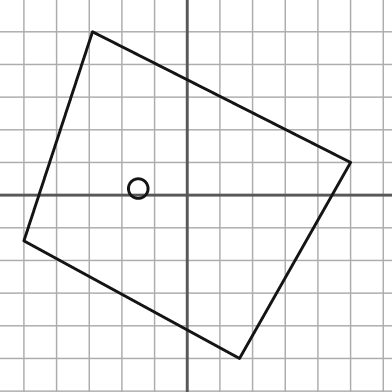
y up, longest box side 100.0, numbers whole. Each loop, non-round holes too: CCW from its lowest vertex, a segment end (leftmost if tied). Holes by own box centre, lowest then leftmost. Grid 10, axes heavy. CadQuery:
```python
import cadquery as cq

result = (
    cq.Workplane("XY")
    .moveTo(16.0, -50.0)
    .lineTo(50.0, 10.0)
    .lineTo(-29.0, 50.0)
    .lineTo(-50.0, -14.0)
    .close()
    .moveTo(-15.0, 2.0)
    .circle(3.0)
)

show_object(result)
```